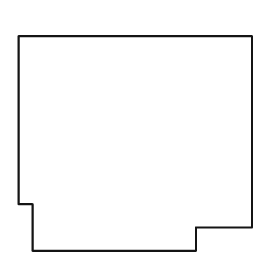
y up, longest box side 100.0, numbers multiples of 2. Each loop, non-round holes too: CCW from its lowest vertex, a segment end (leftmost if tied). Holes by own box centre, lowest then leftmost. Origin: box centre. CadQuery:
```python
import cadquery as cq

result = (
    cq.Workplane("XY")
    .moveTo(-44.0, -46.0)
    .lineTo(26.0, -46.0)
    .lineTo(26.0, -36.0)
    .lineTo(50.0, -36.0)
    .lineTo(50.0, 46.0)
    .lineTo(-50.0, 46.0)
    .lineTo(-50.0, -26.0)
    .lineTo(-44.0, -26.0)
    .close()
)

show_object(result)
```